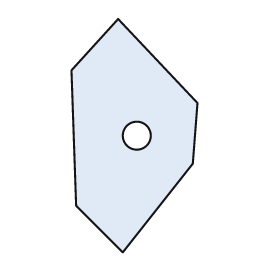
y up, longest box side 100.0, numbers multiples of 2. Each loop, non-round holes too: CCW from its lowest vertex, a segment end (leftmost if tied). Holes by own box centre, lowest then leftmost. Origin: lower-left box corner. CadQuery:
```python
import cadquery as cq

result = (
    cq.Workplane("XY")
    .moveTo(22.0, 0.0)
    .lineTo(52.0, 38.0)
    .lineTo(54.0, 64.0)
    .lineTo(20.0, 100.0)
    .lineTo(0.0, 78.0)
    .lineTo(2.0, 20.0)
    .close()
    .moveTo(28.0, 50.0)
    .circle(6.0)
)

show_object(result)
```